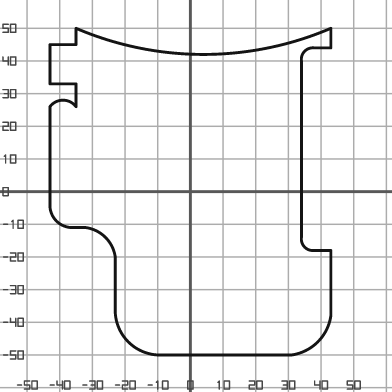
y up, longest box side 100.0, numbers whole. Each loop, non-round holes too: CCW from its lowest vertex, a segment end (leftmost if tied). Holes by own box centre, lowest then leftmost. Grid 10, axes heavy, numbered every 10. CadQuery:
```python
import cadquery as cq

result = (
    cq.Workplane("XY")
    .moveTo(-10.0, -50.0)
    .lineTo(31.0, -50.0)
    .threePointArc((39.0, -46.0), (43.0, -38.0))
    .lineTo(43.0, -18.0)
    .lineTo(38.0, -18.0)
    .threePointArc((35.0, -17.0), (34.0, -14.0))
    .lineTo(34.0, 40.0)
    .threePointArc((35.0, 43.0), (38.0, 44.0))
    .lineTo(43.0, 44.0)
    .lineTo(43.0, 50.0)
    .threePointArc((4.0, 42.0), (-35.0, 50.0))
    .lineTo(-35.0, 45.0)
    .lineTo(-43.0, 45.0)
    .lineTo(-43.0, 33.0)
    .lineTo(-35.0, 33.0)
    .lineTo(-35.0, 26.0)
    .threePointArc((-39.0, 28.0), (-43.0, 26.0))
    .lineTo(-43.0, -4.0)
    .threePointArc((-41.0, -9.0), (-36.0, -11.0))
    .lineTo(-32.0, -11.0)
    .threePointArc((-26.0, -14.0), (-23.0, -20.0))
    .lineTo(-23.0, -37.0)
    .threePointArc((-19.0, -46.0), (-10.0, -50.0))
    .close()
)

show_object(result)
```